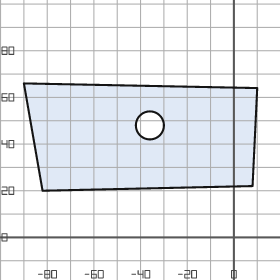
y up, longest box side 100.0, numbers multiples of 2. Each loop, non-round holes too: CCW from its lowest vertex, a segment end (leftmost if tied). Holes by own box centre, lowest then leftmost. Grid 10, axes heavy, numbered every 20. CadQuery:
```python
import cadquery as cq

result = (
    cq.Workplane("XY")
    .moveTo(-82.0, 20.0)
    .lineTo(8.0, 22.0)
    .lineTo(10.0, 64.0)
    .lineTo(-90.0, 66.0)
    .close()
    .moveTo(-36.0, 48.0)
    .circle(6.0)
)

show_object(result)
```